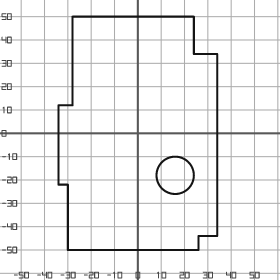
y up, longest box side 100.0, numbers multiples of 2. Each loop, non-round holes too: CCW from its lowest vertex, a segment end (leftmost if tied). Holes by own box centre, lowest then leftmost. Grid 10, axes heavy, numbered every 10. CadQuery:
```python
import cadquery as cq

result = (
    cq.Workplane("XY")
    .moveTo(-30.0, -50.0)
    .lineTo(26.0, -50.0)
    .lineTo(26.0, -44.0)
    .lineTo(34.0, -44.0)
    .lineTo(34.0, 34.0)
    .lineTo(24.0, 34.0)
    .lineTo(24.0, 50.0)
    .lineTo(-28.0, 50.0)
    .lineTo(-28.0, 12.0)
    .lineTo(-34.0, 12.0)
    .lineTo(-34.0, -22.0)
    .lineTo(-30.0, -22.0)
    .close()
    .moveTo(16.0, -18.0)
    .circle(8.0)
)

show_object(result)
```